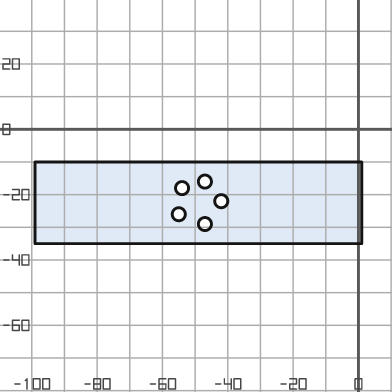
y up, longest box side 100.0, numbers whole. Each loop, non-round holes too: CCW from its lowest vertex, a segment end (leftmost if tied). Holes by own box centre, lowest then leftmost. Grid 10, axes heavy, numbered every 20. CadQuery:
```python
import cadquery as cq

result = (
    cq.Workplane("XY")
    .moveTo(-99.0, -35.0)
    .lineTo(1.0, -35.0)
    .lineTo(1.0, -10.0)
    .lineTo(-99.0, -10.0)
    .close()
    .moveTo(-47.0, -29.0)
    .circle(2.0)
    .moveTo(-55.0, -26.0)
    .circle(2.0)
    .moveTo(-42.0, -22.0)
    .circle(2.0)
    .moveTo(-54.0, -18.0)
    .circle(2.0)
    .moveTo(-47.0, -16.0)
    .circle(2.0)
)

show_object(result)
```